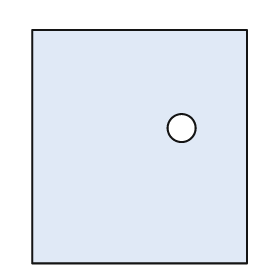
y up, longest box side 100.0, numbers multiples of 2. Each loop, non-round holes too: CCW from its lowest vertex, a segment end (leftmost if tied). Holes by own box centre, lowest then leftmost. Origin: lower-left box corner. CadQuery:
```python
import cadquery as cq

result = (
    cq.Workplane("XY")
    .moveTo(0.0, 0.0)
    .lineTo(92.0, 0.0)
    .lineTo(92.0, 100.0)
    .lineTo(0.0, 100.0)
    .close()
    .moveTo(64.0, 58.0)
    .circle(6.0)
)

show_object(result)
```